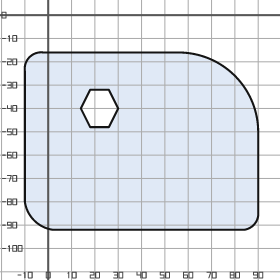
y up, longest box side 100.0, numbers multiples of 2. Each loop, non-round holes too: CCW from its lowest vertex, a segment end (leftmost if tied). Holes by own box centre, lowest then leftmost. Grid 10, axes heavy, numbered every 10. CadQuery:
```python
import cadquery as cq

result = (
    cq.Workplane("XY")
    .moveTo(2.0, -92.0)
    .lineTo(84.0, -92.0)
    .threePointArc((88.0, -90.0), (90.0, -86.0))
    .lineTo(90.0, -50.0)
    .threePointArc((80.0, -26.0), (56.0, -16.0))
    .lineTo(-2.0, -16.0)
    .threePointArc((-8.0, -18.0), (-10.0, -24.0))
    .lineTo(-10.0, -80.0)
    .threePointArc((-6.0, -88.0), (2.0, -92.0))
    .close()
    .moveTo(18.0, -48.0)
    .lineTo(26.0, -48.0)
    .lineTo(30.0, -40.0)
    .lineTo(26.0, -32.0)
    .lineTo(18.0, -32.0)
    .lineTo(14.0, -40.0)
    .close()
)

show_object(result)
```